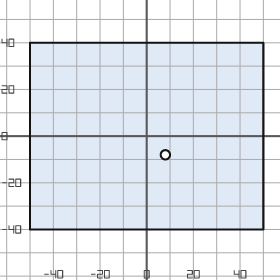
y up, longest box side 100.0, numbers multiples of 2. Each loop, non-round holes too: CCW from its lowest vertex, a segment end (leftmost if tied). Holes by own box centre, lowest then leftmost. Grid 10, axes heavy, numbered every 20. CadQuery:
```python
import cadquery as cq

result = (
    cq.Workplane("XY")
    .moveTo(-50.0, -40.0)
    .lineTo(50.0, -40.0)
    .lineTo(50.0, 40.0)
    .lineTo(-50.0, 40.0)
    .close()
    .moveTo(8.0, -8.0)
    .circle(2.0)
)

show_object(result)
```